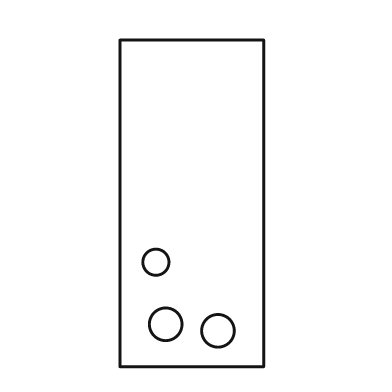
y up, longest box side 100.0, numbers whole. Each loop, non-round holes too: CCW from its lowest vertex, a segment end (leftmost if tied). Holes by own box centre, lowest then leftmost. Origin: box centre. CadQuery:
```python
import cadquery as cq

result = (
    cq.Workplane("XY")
    .moveTo(-22.0, -50.0)
    .lineTo(22.0, -50.0)
    .lineTo(22.0, 50.0)
    .lineTo(-22.0, 50.0)
    .close()
    .moveTo(8.0, -39.0)
    .circle(5.0)
    .moveTo(-8.0, -37.0)
    .circle(5.0)
    .moveTo(-11.0, -18.0)
    .circle(4.0)
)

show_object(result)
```